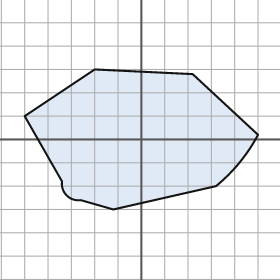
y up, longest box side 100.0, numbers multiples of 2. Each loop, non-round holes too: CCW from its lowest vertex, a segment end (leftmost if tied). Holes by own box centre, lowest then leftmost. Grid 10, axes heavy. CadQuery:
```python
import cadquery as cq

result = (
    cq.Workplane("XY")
    .moveTo(-12.0, -30.0)
    .lineTo(32.0, -20.0)
    .threePointArc((42.0, -10.0), (50.0, 2.0))
    .lineTo(22.0, 28.0)
    .lineTo(-20.0, 30.0)
    .lineTo(-50.0, 10.0)
    .lineTo(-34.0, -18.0)
    .threePointArc((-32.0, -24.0), (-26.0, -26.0))
    .close()
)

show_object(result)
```